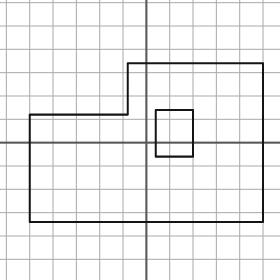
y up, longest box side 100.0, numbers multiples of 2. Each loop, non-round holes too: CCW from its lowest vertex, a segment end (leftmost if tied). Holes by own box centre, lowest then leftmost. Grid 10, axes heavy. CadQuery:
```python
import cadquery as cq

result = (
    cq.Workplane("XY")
    .moveTo(-50.0, -34.0)
    .lineTo(50.0, -34.0)
    .lineTo(50.0, 34.0)
    .lineTo(-8.0, 34.0)
    .lineTo(-8.0, 12.0)
    .lineTo(-50.0, 12.0)
    .close()
    .moveTo(4.0, -6.0)
    .lineTo(20.0, -6.0)
    .lineTo(20.0, 14.0)
    .lineTo(4.0, 14.0)
    .close()
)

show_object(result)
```